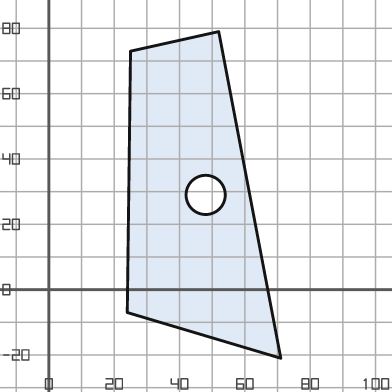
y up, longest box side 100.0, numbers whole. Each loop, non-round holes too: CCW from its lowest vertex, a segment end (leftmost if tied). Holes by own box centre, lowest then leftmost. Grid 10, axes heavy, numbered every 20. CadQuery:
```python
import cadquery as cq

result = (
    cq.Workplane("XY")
    .moveTo(71.0, -21.0)
    .lineTo(52.0, 79.0)
    .lineTo(25.0, 73.0)
    .lineTo(24.0, -7.0)
    .close()
    .moveTo(48.0, 29.0)
    .circle(6.0)
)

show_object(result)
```